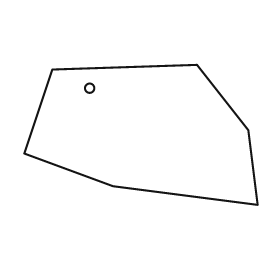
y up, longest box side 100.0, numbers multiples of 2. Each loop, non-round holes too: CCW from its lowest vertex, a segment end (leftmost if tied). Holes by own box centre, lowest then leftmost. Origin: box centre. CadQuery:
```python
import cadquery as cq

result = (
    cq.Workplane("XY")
    .moveTo(50.0, -30.0)
    .lineTo(46.0, 2.0)
    .lineTo(24.0, 30.0)
    .lineTo(-38.0, 28.0)
    .lineTo(-50.0, -8.0)
    .lineTo(-12.0, -22.0)
    .close()
    .moveTo(-22.0, 20.0)
    .circle(2.0)
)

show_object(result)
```